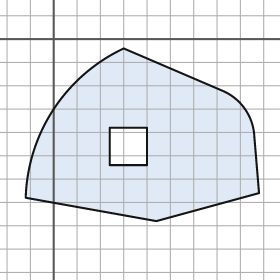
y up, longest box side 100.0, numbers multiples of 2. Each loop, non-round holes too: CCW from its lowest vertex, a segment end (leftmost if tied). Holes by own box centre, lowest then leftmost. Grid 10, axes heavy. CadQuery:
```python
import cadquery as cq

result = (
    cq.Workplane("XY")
    .moveTo(44.0, -78.0)
    .lineTo(88.0, -66.0)
    .lineTo(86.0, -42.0)
    .threePointArc((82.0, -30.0), (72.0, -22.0))
    .lineTo(30.0, -4.0)
    .threePointArc((0.0, -30.0), (-12.0, -68.0))
    .close()
    .moveTo(24.0, -54.0)
    .lineTo(40.0, -54.0)
    .lineTo(40.0, -38.0)
    .lineTo(24.0, -38.0)
    .close()
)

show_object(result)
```